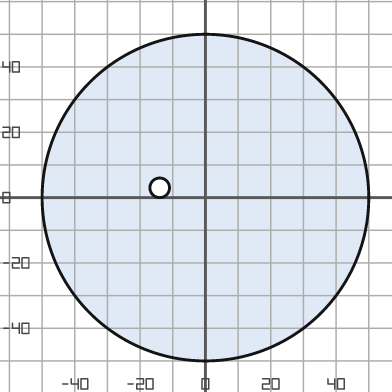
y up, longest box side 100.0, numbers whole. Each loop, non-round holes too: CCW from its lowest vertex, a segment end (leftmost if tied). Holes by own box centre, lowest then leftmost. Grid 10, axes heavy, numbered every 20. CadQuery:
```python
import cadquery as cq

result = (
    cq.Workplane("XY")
    .moveTo(0.0, 0.0)
    .circle(50.0)
    .moveTo(-14.0, 3.0)
    .circle(3.0)
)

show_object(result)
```